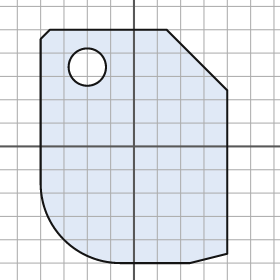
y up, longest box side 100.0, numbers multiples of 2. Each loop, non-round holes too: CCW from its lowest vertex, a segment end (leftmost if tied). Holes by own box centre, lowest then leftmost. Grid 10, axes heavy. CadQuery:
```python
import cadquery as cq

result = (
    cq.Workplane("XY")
    .moveTo(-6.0, -50.0)
    .lineTo(24.0, -50.0)
    .lineTo(40.0, -46.0)
    .lineTo(40.0, 24.0)
    .lineTo(14.0, 50.0)
    .lineTo(-36.0, 50.0)
    .lineTo(-40.0, 46.0)
    .lineTo(-40.0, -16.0)
    .threePointArc((-30.0, -40.0), (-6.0, -50.0))
    .close()
    .moveTo(-20.0, 34.0)
    .circle(8.0)
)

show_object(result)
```